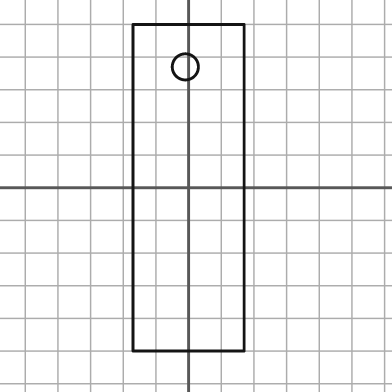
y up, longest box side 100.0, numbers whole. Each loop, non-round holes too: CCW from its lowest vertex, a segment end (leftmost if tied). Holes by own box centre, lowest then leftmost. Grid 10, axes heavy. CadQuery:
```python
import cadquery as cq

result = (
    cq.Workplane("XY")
    .moveTo(-17.0, -50.0)
    .lineTo(17.0, -50.0)
    .lineTo(17.0, 50.0)
    .lineTo(-17.0, 50.0)
    .close()
    .moveTo(-1.0, 37.0)
    .circle(4.0)
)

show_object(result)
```